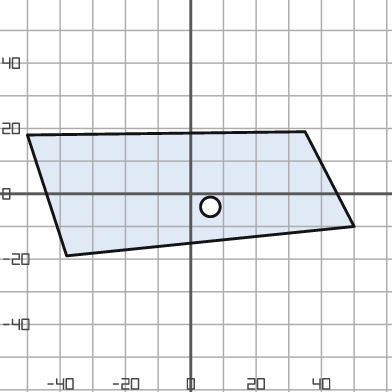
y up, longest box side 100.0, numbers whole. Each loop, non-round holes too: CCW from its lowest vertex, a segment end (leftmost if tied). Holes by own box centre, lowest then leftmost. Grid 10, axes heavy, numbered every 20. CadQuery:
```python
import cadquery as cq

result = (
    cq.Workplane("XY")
    .moveTo(-38.0, -19.0)
    .lineTo(50.0, -10.0)
    .lineTo(35.0, 19.0)
    .lineTo(-50.0, 18.0)
    .close()
    .moveTo(6.0, -4.0)
    .circle(3.0)
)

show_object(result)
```